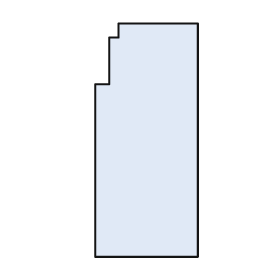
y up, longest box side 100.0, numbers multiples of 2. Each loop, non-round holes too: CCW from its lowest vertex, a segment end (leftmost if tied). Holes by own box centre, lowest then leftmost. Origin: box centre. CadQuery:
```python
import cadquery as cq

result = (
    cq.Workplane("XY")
    .moveTo(-22.0, -50.0)
    .lineTo(22.0, -50.0)
    .lineTo(22.0, 50.0)
    .lineTo(-12.0, 50.0)
    .lineTo(-12.0, 44.0)
    .lineTo(-16.0, 44.0)
    .lineTo(-16.0, 24.0)
    .lineTo(-22.0, 24.0)
    .close()
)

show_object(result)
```